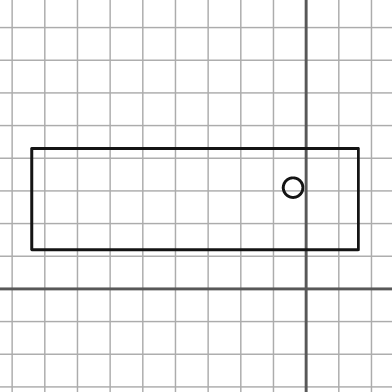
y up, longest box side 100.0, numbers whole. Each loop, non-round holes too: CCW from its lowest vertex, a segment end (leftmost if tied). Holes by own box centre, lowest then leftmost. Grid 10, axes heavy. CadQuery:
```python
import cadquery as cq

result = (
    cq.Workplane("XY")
    .moveTo(-84.0, 12.0)
    .lineTo(16.0, 12.0)
    .lineTo(16.0, 43.0)
    .lineTo(-84.0, 43.0)
    .close()
    .moveTo(-4.0, 31.0)
    .circle(3.0)
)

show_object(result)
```